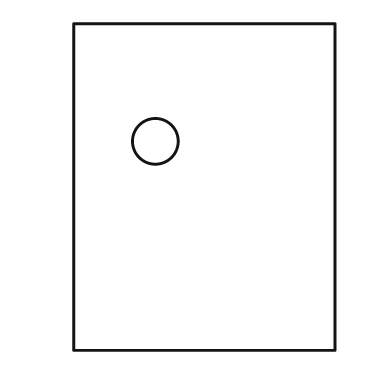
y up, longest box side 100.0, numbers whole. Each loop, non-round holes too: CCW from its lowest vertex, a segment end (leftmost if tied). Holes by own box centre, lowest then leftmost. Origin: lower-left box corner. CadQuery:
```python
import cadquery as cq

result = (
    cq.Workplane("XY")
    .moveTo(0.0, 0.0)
    .lineTo(80.0, 0.0)
    .lineTo(80.0, 100.0)
    .lineTo(0.0, 100.0)
    .close()
    .moveTo(25.0, 64.0)
    .circle(7.0)
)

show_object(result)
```